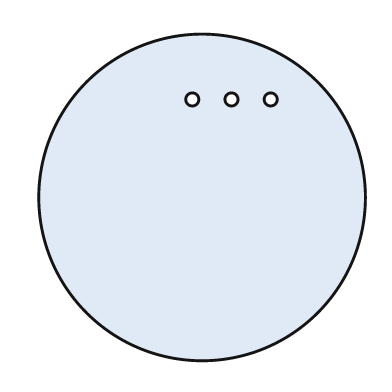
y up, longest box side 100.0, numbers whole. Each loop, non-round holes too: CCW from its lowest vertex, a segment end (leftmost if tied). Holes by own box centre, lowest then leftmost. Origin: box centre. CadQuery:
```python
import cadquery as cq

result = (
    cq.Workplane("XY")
    .moveTo(0.0, 0.0)
    .circle(50.0)
    .moveTo(-3.0, 30.0)
    .circle(2.0)
    .moveTo(9.0, 30.0)
    .circle(2.0)
    .moveTo(21.0, 30.0)
    .circle(2.0)
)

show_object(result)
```